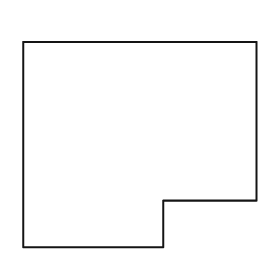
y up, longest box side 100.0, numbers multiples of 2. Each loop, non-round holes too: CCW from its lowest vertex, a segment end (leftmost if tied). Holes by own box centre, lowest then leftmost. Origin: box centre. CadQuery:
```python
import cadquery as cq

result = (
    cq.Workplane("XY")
    .moveTo(-50.0, -44.0)
    .lineTo(10.0, -44.0)
    .lineTo(10.0, -24.0)
    .lineTo(50.0, -24.0)
    .lineTo(50.0, 44.0)
    .lineTo(-50.0, 44.0)
    .close()
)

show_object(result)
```